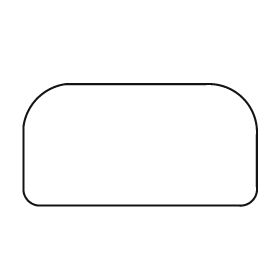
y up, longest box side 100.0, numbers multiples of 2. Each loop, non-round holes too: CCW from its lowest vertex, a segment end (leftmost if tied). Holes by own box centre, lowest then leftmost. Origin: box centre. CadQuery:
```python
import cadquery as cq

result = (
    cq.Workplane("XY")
    .moveTo(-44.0, -26.0)
    .lineTo(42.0, -26.0)
    .threePointArc((48.0, -24.0), (50.0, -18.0))
    .lineTo(50.0, 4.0)
    .threePointArc((44.0, 20.0), (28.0, 26.0))
    .lineTo(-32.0, 26.0)
    .threePointArc((-44.0, 20.0), (-50.0, 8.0))
    .lineTo(-50.0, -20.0)
    .threePointArc((-48.0, -24.0), (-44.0, -26.0))
    .close()
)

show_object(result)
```